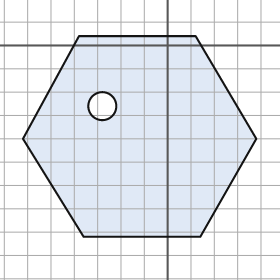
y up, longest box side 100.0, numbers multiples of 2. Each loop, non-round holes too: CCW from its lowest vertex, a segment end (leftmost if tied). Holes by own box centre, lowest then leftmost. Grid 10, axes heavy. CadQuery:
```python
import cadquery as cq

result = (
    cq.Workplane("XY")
    .moveTo(-36.0, -82.0)
    .lineTo(14.0, -82.0)
    .lineTo(38.0, -40.0)
    .lineTo(12.0, 4.0)
    .lineTo(-38.0, 4.0)
    .lineTo(-62.0, -40.0)
    .close()
    .moveTo(-28.0, -26.0)
    .circle(6.0)
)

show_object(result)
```